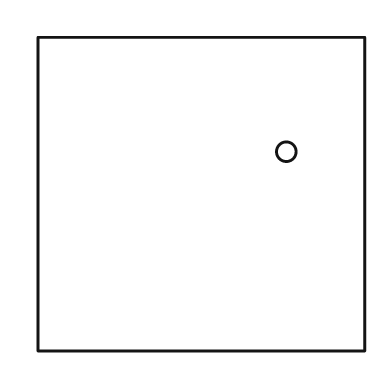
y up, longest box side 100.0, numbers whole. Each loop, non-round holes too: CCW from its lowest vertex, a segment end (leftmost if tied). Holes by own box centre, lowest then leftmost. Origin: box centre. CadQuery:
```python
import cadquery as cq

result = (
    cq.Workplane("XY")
    .moveTo(-50.0, -48.0)
    .lineTo(50.0, -48.0)
    .lineTo(50.0, 48.0)
    .lineTo(-50.0, 48.0)
    .close()
    .moveTo(26.0, 13.0)
    .circle(3.0)
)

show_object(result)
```